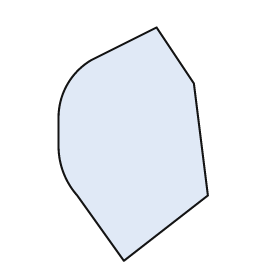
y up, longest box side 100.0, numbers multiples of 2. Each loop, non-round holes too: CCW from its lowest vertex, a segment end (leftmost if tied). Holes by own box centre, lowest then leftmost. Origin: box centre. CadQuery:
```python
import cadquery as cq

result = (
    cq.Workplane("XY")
    .moveTo(-4.0, -50.0)
    .lineTo(32.0, -22.0)
    .lineTo(26.0, 26.0)
    .lineTo(10.0, 50.0)
    .lineTo(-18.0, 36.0)
    .threePointArc((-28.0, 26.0), (-32.0, 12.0))
    .lineTo(-32.0, 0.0)
    .threePointArc((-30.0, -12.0), (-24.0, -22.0))
    .close()
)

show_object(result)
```